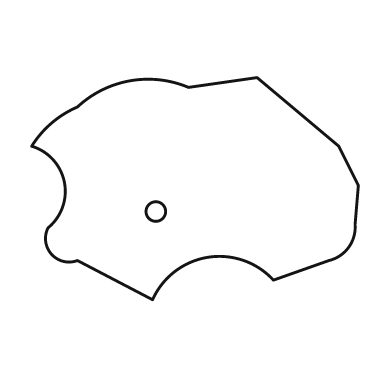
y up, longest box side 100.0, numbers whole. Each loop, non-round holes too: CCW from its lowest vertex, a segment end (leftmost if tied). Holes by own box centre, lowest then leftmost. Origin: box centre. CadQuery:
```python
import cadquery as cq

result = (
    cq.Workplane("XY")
    .moveTo(-13.0, -34.0)
    .threePointArc((4.0, -21.0), (24.0, -28.0))
    .lineTo(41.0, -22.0)
    .threePointArc((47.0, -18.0), (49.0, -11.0))
    .lineTo(50.0, 1.0)
    .lineTo(44.0, 13.0)
    .lineTo(19.0, 34.0)
    .lineTo(-2.0, 31.0)
    .threePointArc((-20.0, 33.0), (-36.0, 25.0))
    .threePointArc((-44.0, 20.0), (-50.0, 13.0))
    .threePointArc((-40.0, 2.0), (-45.0, -12.0))
    .threePointArc((-44.0, -20.0), (-36.0, -22.0))
    .close()
    .moveTo(-12.0, -7.0)
    .circle(3.0)
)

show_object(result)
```